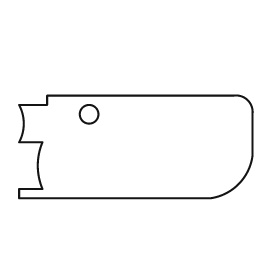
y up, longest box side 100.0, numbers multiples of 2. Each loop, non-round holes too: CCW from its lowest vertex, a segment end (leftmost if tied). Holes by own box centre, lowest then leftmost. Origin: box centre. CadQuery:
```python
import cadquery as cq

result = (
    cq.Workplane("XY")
    .moveTo(-50.0, -22.0)
    .lineTo(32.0, -22.0)
    .threePointArc((44.0, -16.0), (50.0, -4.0))
    .lineTo(50.0, 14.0)
    .threePointArc((48.0, 20.0), (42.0, 22.0))
    .lineTo(-38.0, 22.0)
    .lineTo(-38.0, 18.0)
    .lineTo(-50.0, 18.0)
    .threePointArc((-48.0, 10.0), (-50.0, 2.0))
    .lineTo(-40.0, 2.0)
    .threePointArc((-42.0, -8.0), (-40.0, -18.0))
    .lineTo(-50.0, -18.0)
    .close()
    .moveTo(-20.0, 14.0)
    .circle(4.0)
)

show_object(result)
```